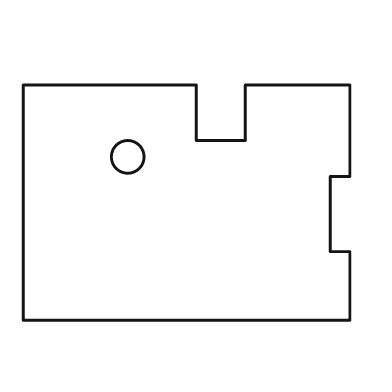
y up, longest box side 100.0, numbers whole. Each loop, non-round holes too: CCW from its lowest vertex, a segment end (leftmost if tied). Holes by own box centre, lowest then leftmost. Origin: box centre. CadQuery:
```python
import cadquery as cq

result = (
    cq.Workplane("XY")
    .moveTo(-50.0, -36.0)
    .lineTo(50.0, -36.0)
    .lineTo(50.0, -15.0)
    .lineTo(44.0, -15.0)
    .lineTo(44.0, 8.0)
    .lineTo(50.0, 8.0)
    .lineTo(50.0, 36.0)
    .lineTo(18.0, 36.0)
    .lineTo(18.0, 19.0)
    .lineTo(3.0, 19.0)
    .lineTo(3.0, 36.0)
    .lineTo(-50.0, 36.0)
    .close()
    .moveTo(-18.0, 14.0)
    .circle(5.0)
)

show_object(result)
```